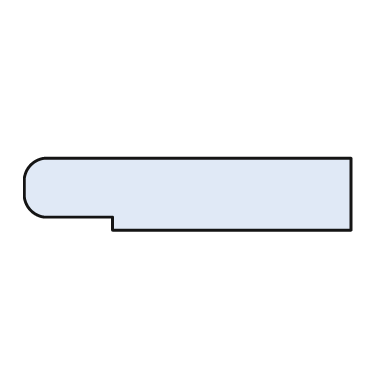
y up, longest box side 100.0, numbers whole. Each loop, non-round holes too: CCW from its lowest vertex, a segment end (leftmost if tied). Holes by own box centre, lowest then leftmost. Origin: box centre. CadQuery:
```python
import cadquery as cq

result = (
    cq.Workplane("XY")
    .moveTo(-23.0, -11.0)
    .lineTo(50.0, -11.0)
    .lineTo(50.0, 11.0)
    .lineTo(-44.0, 11.0)
    .threePointArc((-48.0, 9.0), (-50.0, 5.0))
    .lineTo(-50.0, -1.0)
    .threePointArc((-48.0, -5.0), (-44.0, -7.0))
    .lineTo(-23.0, -7.0)
    .close()
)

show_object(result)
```